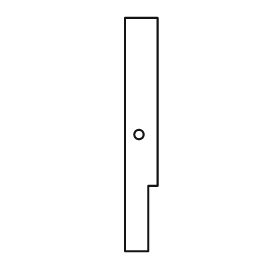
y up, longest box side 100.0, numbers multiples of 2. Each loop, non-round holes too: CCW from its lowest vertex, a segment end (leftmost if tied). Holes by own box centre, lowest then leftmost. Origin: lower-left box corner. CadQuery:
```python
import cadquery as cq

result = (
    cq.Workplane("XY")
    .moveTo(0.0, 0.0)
    .lineTo(10.0, 0.0)
    .lineTo(10.0, 28.0)
    .lineTo(14.0, 28.0)
    .lineTo(14.0, 100.0)
    .lineTo(0.0, 100.0)
    .close()
    .moveTo(6.0, 50.0)
    .circle(2.0)
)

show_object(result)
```